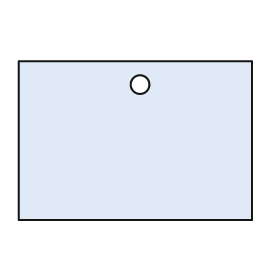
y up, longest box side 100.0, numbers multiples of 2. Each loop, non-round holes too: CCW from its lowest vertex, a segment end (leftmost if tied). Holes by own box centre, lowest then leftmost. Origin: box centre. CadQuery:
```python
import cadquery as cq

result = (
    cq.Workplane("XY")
    .moveTo(-50.0, -34.0)
    .lineTo(50.0, -34.0)
    .lineTo(50.0, 34.0)
    .lineTo(-50.0, 34.0)
    .close()
    .moveTo(2.0, 24.0)
    .circle(4.0)
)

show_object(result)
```